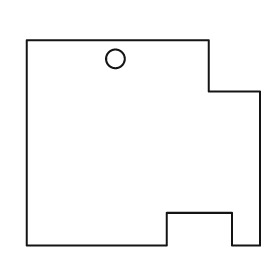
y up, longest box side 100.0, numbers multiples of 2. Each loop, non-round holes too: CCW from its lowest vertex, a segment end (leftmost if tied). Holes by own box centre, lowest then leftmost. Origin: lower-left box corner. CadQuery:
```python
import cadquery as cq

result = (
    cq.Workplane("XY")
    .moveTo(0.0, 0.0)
    .lineTo(60.0, 0.0)
    .lineTo(60.0, 14.0)
    .lineTo(88.0, 14.0)
    .lineTo(88.0, 0.0)
    .lineTo(100.0, 0.0)
    .lineTo(100.0, 66.0)
    .lineTo(78.0, 66.0)
    .lineTo(78.0, 88.0)
    .lineTo(0.0, 88.0)
    .close()
    .moveTo(38.0, 80.0)
    .circle(4.0)
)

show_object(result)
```